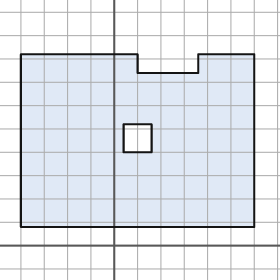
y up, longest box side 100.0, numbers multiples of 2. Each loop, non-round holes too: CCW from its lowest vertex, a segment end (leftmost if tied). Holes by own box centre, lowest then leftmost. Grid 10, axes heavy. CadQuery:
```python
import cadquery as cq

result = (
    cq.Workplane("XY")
    .moveTo(-40.0, 8.0)
    .lineTo(60.0, 8.0)
    .lineTo(60.0, 82.0)
    .lineTo(36.0, 82.0)
    .lineTo(36.0, 74.0)
    .lineTo(10.0, 74.0)
    .lineTo(10.0, 82.0)
    .lineTo(-40.0, 82.0)
    .close()
    .moveTo(4.0, 40.0)
    .lineTo(16.0, 40.0)
    .lineTo(16.0, 52.0)
    .lineTo(4.0, 52.0)
    .close()
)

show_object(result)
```